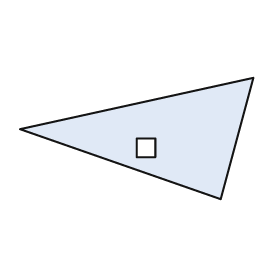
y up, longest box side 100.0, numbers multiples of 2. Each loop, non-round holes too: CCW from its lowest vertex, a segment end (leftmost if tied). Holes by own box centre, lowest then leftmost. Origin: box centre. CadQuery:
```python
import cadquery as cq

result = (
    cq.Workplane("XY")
    .moveTo(36.0, -26.0)
    .lineTo(50.0, 26.0)
    .lineTo(-50.0, 4.0)
    .close()
    .moveTo(0.0, -8.0)
    .lineTo(8.0, -8.0)
    .lineTo(8.0, 0.0)
    .lineTo(0.0, 0.0)
    .close()
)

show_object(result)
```